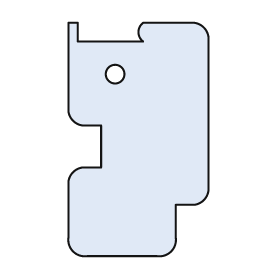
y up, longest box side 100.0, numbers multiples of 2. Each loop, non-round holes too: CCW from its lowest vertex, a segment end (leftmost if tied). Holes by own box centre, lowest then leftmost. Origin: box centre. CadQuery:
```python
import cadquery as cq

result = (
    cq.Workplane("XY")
    .moveTo(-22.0, -50.0)
    .lineTo(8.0, -50.0)
    .threePointArc((14.0, -48.0), (16.0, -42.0))
    .lineTo(16.0, -28.0)
    .lineTo(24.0, -28.0)
    .threePointArc((28.0, -26.0), (30.0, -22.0))
    .lineTo(30.0, 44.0)
    .threePointArc((28.0, 48.0), (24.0, 50.0))
    .lineTo(2.0, 50.0)
    .threePointArc((0.0, 46.0), (2.0, 42.0))
    .lineTo(-26.0, 42.0)
    .lineTo(-26.0, 50.0)
    .lineTo(-30.0, 50.0)
    .lineTo(-30.0, 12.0)
    .threePointArc((-28.0, 8.0), (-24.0, 6.0))
    .lineTo(-16.0, 6.0)
    .lineTo(-16.0, -12.0)
    .lineTo(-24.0, -12.0)
    .threePointArc((-28.0, -14.0), (-30.0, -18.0))
    .lineTo(-30.0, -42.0)
    .threePointArc((-28.0, -48.0), (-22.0, -50.0))
    .close()
    .moveTo(-10.0, 28.0)
    .circle(4.0)
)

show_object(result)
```